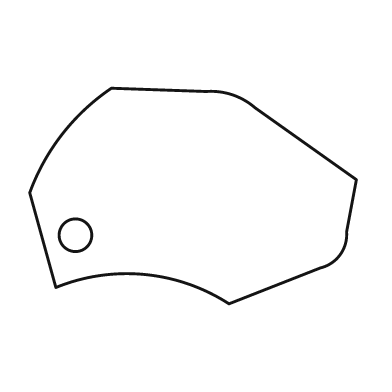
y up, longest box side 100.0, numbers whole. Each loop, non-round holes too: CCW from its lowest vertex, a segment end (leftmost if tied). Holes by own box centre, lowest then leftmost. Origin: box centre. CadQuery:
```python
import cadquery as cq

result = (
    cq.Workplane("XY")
    .moveTo(11.0, -33.0)
    .lineTo(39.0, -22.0)
    .threePointArc((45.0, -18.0), (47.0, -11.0))
    .lineTo(50.0, 5.0)
    .lineTo(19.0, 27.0)
    .threePointArc((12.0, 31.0), (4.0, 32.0))
    .lineTo(-25.0, 33.0)
    .threePointArc((-40.0, 19.0), (-50.0, 1.0))
    .lineTo(-42.0, -28.0)
    .threePointArc((-15.0, -24.0), (11.0, -33.0))
    .close()
    .moveTo(-36.0, -12.0)
    .circle(5.0)
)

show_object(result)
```